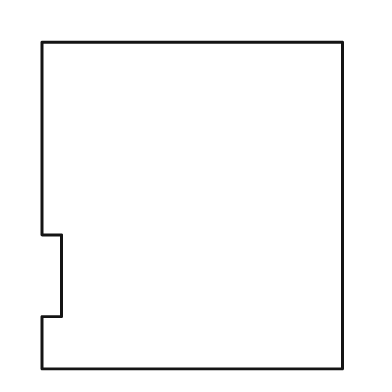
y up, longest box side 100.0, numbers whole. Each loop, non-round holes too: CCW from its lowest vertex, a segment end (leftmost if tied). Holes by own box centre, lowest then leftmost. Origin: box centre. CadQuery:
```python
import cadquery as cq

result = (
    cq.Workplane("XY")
    .moveTo(-46.0, -50.0)
    .lineTo(46.0, -50.0)
    .lineTo(46.0, 50.0)
    .lineTo(-46.0, 50.0)
    .lineTo(-46.0, -9.0)
    .lineTo(-40.0, -9.0)
    .lineTo(-40.0, -34.0)
    .lineTo(-46.0, -34.0)
    .close()
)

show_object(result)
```